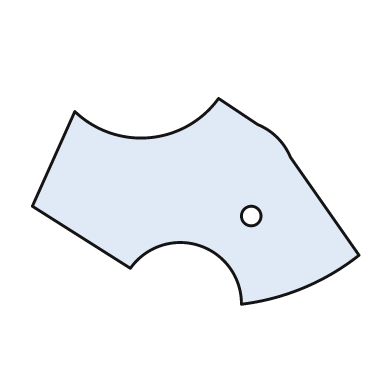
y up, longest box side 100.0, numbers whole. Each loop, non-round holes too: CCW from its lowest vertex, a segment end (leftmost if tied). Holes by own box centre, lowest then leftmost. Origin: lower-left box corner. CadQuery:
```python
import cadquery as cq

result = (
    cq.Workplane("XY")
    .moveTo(64.0, 0.0)
    .threePointArc((83.0, 5.0), (100.0, 15.0))
    .lineTo(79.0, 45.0)
    .threePointArc((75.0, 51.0), (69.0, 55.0))
    .lineTo(57.0, 63.0)
    .threePointArc((36.0, 51.0), (13.0, 59.0))
    .lineTo(0.0, 30.0)
    .lineTo(30.0, 11.0)
    .threePointArc((51.0, 18.0), (64.0, 0.0))
    .close()
    .moveTo(67.0, 27.0)
    .circle(3.0)
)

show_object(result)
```